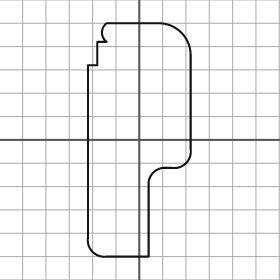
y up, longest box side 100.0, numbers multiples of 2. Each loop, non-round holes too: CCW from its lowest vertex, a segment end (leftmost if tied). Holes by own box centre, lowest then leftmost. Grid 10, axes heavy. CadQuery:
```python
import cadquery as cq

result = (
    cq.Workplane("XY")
    .moveTo(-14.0, -50.0)
    .lineTo(4.0, -50.0)
    .lineTo(4.0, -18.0)
    .threePointArc((6.0, -14.0), (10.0, -12.0))
    .lineTo(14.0, -12.0)
    .threePointArc((20.0, -10.0), (22.0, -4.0))
    .lineTo(22.0, 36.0)
    .threePointArc((18.0, 46.0), (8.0, 50.0))
    .lineTo(-14.0, 50.0)
    .threePointArc((-16.0, 46.0), (-14.0, 42.0))
    .lineTo(-18.0, 42.0)
    .lineTo(-18.0, 32.0)
    .lineTo(-22.0, 32.0)
    .lineTo(-22.0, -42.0)
    .threePointArc((-20.0, -48.0), (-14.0, -50.0))
    .close()
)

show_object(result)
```